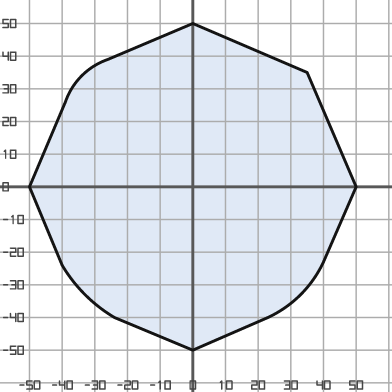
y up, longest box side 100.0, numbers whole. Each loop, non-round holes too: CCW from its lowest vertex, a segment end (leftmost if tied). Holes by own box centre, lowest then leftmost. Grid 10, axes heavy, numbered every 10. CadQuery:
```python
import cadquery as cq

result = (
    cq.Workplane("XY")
    .moveTo(0.0, -50.0)
    .lineTo(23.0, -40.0)
    .threePointArc((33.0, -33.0), (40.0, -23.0))
    .lineTo(50.0, 0.0)
    .lineTo(35.0, 35.0)
    .lineTo(0.0, 50.0)
    .lineTo(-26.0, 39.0)
    .threePointArc((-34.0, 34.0), (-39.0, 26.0))
    .lineTo(-50.0, 0.0)
    .lineTo(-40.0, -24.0)
    .threePointArc((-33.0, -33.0), (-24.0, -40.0))
    .close()
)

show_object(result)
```